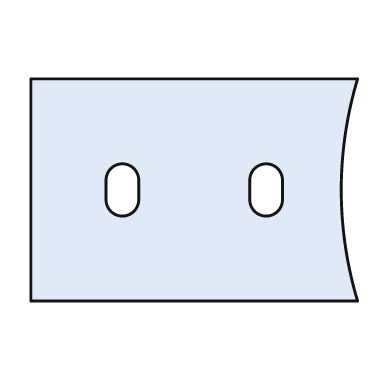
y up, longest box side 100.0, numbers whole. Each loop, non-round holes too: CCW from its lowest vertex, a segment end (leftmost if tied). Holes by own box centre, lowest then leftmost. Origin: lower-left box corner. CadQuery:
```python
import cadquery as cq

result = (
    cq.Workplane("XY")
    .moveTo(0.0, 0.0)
    .lineTo(100.0, 0.0)
    .threePointArc((95.0, 34.0), (100.0, 68.0))
    .lineTo(0.0, 68.0)
    .close()
    .moveTo(23.0, 31.0)
    .threePointArc((28.0, 26.0), (33.0, 31.0))
    .lineTo(33.0, 37.0)
    .threePointArc((28.0, 42.0), (23.0, 37.0))
    .close()
    .moveTo(67.0, 31.0)
    .threePointArc((72.0, 26.0), (77.0, 31.0))
    .lineTo(77.0, 37.0)
    .threePointArc((72.0, 42.0), (67.0, 37.0))
    .close()
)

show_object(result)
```